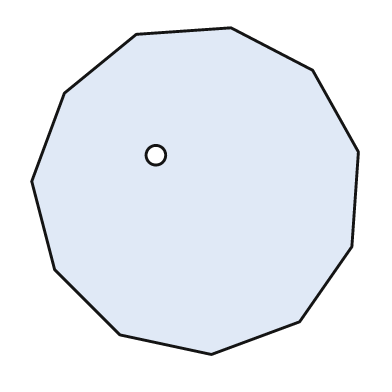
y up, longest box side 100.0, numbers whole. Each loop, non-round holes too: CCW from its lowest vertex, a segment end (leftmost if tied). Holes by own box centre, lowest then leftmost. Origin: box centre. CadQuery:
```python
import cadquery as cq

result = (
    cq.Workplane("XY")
    .moveTo(5.0, -50.0)
    .lineTo(32.0, -40.0)
    .lineTo(48.0, -17.0)
    .lineTo(50.0, 12.0)
    .lineTo(36.0, 37.0)
    .lineTo(11.0, 50.0)
    .lineTo(-18.0, 48.0)
    .lineTo(-40.0, 30.0)
    .lineTo(-50.0, 3.0)
    .lineTo(-43.0, -24.0)
    .lineTo(-23.0, -44.0)
    .close()
    .moveTo(-12.0, 11.0)
    .circle(3.0)
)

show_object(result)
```